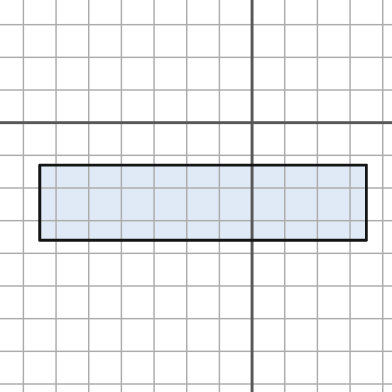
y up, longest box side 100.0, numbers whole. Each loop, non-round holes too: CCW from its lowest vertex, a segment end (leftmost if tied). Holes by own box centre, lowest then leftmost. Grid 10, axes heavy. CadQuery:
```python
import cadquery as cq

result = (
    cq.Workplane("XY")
    .moveTo(-65.0, -36.0)
    .lineTo(35.0, -36.0)
    .lineTo(35.0, -13.0)
    .lineTo(-65.0, -13.0)
    .close()
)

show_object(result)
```